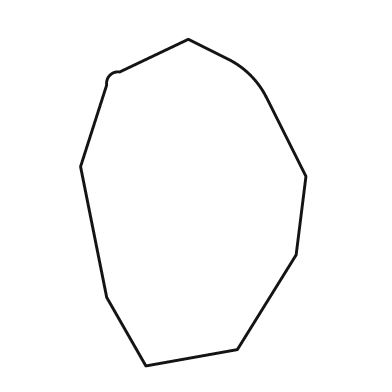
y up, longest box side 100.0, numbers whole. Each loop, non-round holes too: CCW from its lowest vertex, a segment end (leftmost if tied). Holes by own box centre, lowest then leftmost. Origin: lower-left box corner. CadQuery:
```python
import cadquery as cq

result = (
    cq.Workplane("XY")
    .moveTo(20.0, 0.0)
    .lineTo(48.0, 5.0)
    .lineTo(66.0, 34.0)
    .lineTo(69.0, 58.0)
    .lineTo(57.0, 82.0)
    .threePointArc((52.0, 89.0), (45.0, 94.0))
    .lineTo(33.0, 100.0)
    .lineTo(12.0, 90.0)
    .threePointArc((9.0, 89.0), (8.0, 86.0))
    .lineTo(0.0, 61.0)
    .lineTo(8.0, 21.0)
    .close()
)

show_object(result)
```